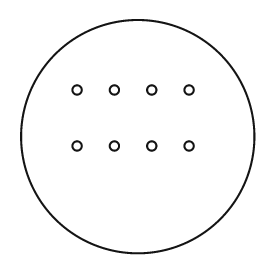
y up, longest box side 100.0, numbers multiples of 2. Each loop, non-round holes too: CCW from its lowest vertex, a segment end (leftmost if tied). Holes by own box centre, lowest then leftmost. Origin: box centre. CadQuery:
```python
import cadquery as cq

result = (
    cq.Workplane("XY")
    .moveTo(0.0, 0.0)
    .circle(50.0)
    .moveTo(-26.0, -4.0)
    .circle(2.0)
    .moveTo(-10.0, -4.0)
    .circle(2.0)
    .moveTo(6.0, -4.0)
    .circle(2.0)
    .moveTo(22.0, -4.0)
    .circle(2.0)
    .moveTo(-26.0, 20.0)
    .circle(2.0)
    .moveTo(-10.0, 20.0)
    .circle(2.0)
    .moveTo(6.0, 20.0)
    .circle(2.0)
    .moveTo(22.0, 20.0)
    .circle(2.0)
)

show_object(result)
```